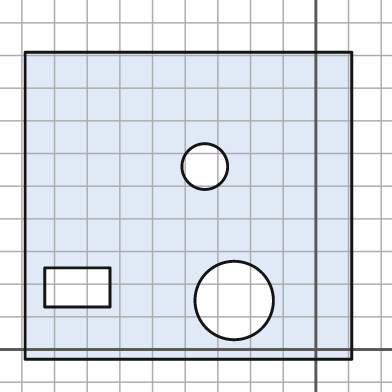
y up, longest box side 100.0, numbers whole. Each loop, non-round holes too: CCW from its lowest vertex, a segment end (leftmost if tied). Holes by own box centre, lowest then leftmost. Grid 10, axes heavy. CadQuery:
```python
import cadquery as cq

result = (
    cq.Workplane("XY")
    .moveTo(-89.0, -3.0)
    .lineTo(11.0, -3.0)
    .lineTo(11.0, 91.0)
    .lineTo(-89.0, 91.0)
    .close()
    .moveTo(-25.0, 15.0)
    .circle(12.0)
    .moveTo(-83.0, 13.0)
    .lineTo(-63.0, 13.0)
    .lineTo(-63.0, 25.0)
    .lineTo(-83.0, 25.0)
    .close()
    .moveTo(-34.0, 56.0)
    .circle(7.0)
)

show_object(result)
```